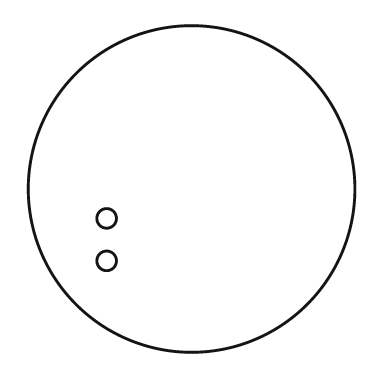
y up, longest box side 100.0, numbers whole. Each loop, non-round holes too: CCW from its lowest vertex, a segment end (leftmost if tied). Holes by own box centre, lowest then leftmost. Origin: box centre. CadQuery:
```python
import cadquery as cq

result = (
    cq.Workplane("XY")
    .moveTo(0.0, 0.0)
    .circle(50.0)
    .moveTo(-26.0, -22.0)
    .circle(3.0)
    .moveTo(-26.0, -9.0)
    .circle(3.0)
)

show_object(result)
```